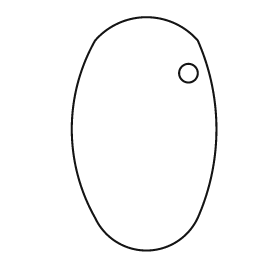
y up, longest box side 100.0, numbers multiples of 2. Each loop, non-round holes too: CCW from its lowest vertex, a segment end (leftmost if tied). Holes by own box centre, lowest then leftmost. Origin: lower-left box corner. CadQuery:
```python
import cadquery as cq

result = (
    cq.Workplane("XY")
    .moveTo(10.0, 14.0)
    .threePointArc((32.0, 0.0), (54.0, 14.0))
    .threePointArc((62.0, 52.0), (54.0, 90.0))
    .threePointArc((32.0, 100.0), (10.0, 90.0))
    .threePointArc((0.0, 52.0), (10.0, 14.0))
    .close()
    .moveTo(50.0, 76.0)
    .circle(4.0)
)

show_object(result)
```